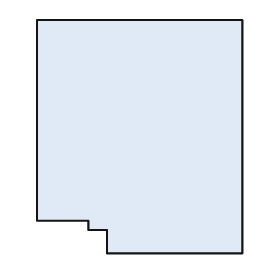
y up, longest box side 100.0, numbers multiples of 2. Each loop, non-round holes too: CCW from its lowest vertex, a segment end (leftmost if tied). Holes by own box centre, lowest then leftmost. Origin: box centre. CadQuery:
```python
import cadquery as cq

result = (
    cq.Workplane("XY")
    .moveTo(-14.0, -50.0)
    .lineTo(44.0, -50.0)
    .lineTo(44.0, 50.0)
    .lineTo(-44.0, 50.0)
    .lineTo(-44.0, -36.0)
    .lineTo(-22.0, -36.0)
    .lineTo(-22.0, -40.0)
    .lineTo(-14.0, -40.0)
    .close()
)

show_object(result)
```